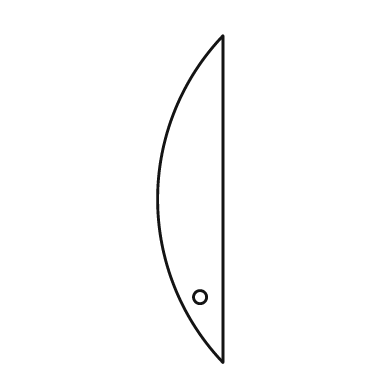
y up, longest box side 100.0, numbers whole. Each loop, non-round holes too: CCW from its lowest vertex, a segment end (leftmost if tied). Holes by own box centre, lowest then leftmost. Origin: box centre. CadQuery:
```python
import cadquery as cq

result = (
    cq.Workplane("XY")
    .moveTo(10.0, -50.0)
    .lineTo(10.0, 50.0)
    .threePointArc((-10.0, 0.0), (10.0, -50.0))
    .close()
    .moveTo(3.0, -30.0)
    .circle(2.0)
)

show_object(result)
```